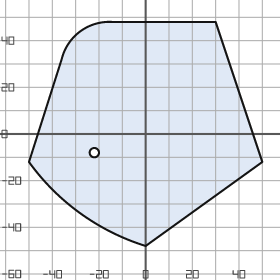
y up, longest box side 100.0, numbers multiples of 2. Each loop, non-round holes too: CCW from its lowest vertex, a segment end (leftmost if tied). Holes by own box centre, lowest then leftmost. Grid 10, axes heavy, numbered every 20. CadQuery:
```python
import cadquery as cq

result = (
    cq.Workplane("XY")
    .moveTo(0.0, -48.0)
    .lineTo(50.0, -12.0)
    .lineTo(30.0, 48.0)
    .lineTo(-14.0, 48.0)
    .threePointArc((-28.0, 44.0), (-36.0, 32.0))
    .lineTo(-50.0, -12.0)
    .threePointArc((-28.0, -34.0), (0.0, -48.0))
    .close()
    .moveTo(-22.0, -8.0)
    .circle(2.0)
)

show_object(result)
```